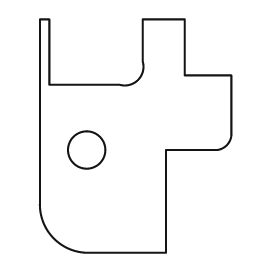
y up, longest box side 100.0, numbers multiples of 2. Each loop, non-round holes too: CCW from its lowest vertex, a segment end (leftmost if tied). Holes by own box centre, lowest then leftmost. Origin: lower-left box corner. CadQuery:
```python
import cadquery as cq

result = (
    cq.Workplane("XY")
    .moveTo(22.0, 0.0)
    .lineTo(54.0, 0.0)
    .lineTo(54.0, 44.0)
    .lineTo(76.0, 44.0)
    .threePointArc((80.0, 46.0), (82.0, 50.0))
    .lineTo(82.0, 76.0)
    .lineTo(62.0, 76.0)
    .lineTo(62.0, 100.0)
    .lineTo(44.0, 100.0)
    .lineTo(44.0, 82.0)
    .threePointArc((42.0, 74.0), (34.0, 72.0))
    .lineTo(4.0, 72.0)
    .lineTo(4.0, 100.0)
    .lineTo(0.0, 100.0)
    .lineTo(0.0, 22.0)
    .threePointArc((6.0, 6.0), (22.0, 0.0))
    .close()
    .moveTo(20.0, 44.0)
    .circle(8.0)
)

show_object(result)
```